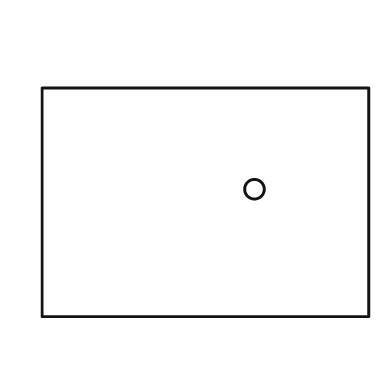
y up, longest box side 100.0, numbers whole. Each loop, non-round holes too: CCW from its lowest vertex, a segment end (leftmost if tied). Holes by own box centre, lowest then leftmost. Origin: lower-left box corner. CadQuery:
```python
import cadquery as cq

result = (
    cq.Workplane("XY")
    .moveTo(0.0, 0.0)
    .lineTo(100.0, 0.0)
    .lineTo(100.0, 70.0)
    .lineTo(0.0, 70.0)
    .close()
    .moveTo(65.0, 39.0)
    .circle(3.0)
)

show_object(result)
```